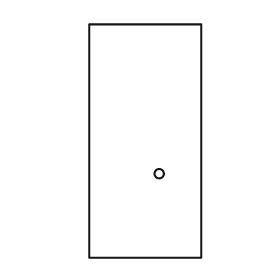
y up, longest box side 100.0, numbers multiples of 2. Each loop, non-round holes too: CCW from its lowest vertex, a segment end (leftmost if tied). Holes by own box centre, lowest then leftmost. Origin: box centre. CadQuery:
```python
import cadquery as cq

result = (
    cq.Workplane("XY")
    .moveTo(-24.0, -50.0)
    .lineTo(24.0, -50.0)
    .lineTo(24.0, 50.0)
    .lineTo(-24.0, 50.0)
    .close()
    .moveTo(6.0, -14.0)
    .circle(2.0)
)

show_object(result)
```